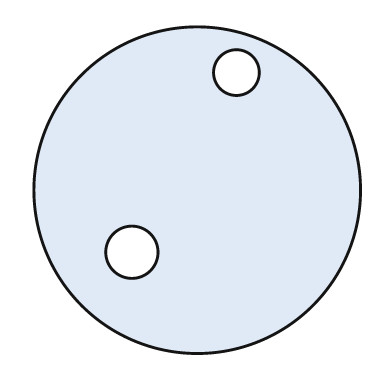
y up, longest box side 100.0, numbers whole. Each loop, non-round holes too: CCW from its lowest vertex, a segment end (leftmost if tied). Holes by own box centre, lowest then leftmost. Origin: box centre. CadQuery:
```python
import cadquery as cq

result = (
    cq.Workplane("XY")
    .moveTo(0.0, 0.0)
    .circle(50.0)
    .moveTo(-20.0, -19.0)
    .circle(8.0)
    .moveTo(12.0, 36.0)
    .circle(7.0)
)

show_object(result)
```